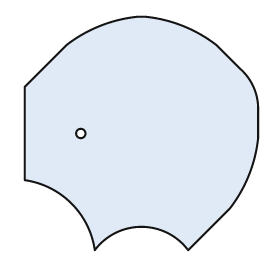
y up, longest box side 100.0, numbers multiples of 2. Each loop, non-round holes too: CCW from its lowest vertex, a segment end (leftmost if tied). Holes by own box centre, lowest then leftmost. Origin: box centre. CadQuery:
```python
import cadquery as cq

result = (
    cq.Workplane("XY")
    .moveTo(-20.0, -50.0)
    .threePointArc((0.0, -40.0), (20.0, -50.0))
    .lineTo(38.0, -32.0)
    .threePointArc((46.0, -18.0), (50.0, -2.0))
    .lineTo(50.0, 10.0)
    .threePointArc((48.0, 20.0), (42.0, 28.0))
    .lineTo(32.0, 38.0)
    .threePointArc((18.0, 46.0), (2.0, 50.0))
    .lineTo(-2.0, 50.0)
    .threePointArc((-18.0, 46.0), (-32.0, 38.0))
    .lineTo(-50.0, 20.0)
    .lineTo(-50.0, -20.0)
    .threePointArc((-30.0, -30.0), (-20.0, -50.0))
    .close()
    .moveTo(-26.0, 0.0)
    .circle(2.0)
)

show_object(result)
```